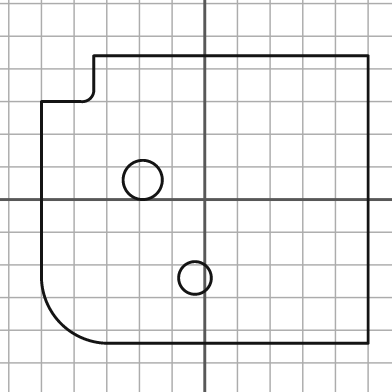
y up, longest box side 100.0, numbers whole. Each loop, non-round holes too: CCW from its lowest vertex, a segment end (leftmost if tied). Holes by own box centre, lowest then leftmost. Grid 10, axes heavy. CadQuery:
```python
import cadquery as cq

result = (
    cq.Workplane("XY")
    .moveTo(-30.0, -44.0)
    .lineTo(50.0, -44.0)
    .lineTo(50.0, 44.0)
    .lineTo(-34.0, 44.0)
    .lineTo(-34.0, 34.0)
    .threePointArc((-35.0, 31.0), (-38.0, 30.0))
    .lineTo(-50.0, 30.0)
    .lineTo(-50.0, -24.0)
    .threePointArc((-44.0, -38.0), (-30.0, -44.0))
    .close()
    .moveTo(-3.0, -24.0)
    .circle(5.0)
    .moveTo(-19.0, 6.0)
    .circle(6.0)
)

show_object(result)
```